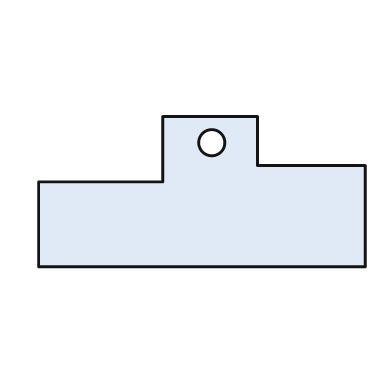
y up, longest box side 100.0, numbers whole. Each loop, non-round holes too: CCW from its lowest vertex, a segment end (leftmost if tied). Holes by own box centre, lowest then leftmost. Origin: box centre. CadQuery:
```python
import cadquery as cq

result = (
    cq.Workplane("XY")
    .moveTo(-50.0, -23.0)
    .lineTo(50.0, -23.0)
    .lineTo(50.0, 8.0)
    .lineTo(17.0, 8.0)
    .lineTo(17.0, 23.0)
    .lineTo(-12.0, 23.0)
    .lineTo(-12.0, 3.0)
    .lineTo(-50.0, 3.0)
    .close()
    .moveTo(3.0, 15.0)
    .circle(4.0)
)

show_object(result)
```